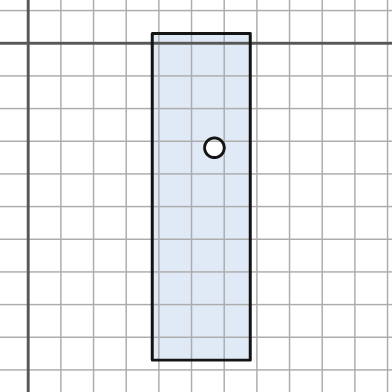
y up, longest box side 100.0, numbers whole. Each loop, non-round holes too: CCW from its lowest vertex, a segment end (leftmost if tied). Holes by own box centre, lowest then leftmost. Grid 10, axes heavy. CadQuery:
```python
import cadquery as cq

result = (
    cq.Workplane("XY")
    .moveTo(38.0, -97.0)
    .lineTo(68.0, -97.0)
    .lineTo(68.0, 3.0)
    .lineTo(38.0, 3.0)
    .close()
    .moveTo(57.0, -32.0)
    .circle(3.0)
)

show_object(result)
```